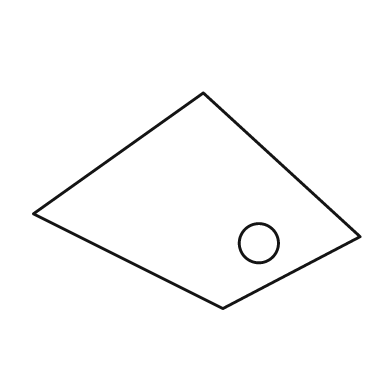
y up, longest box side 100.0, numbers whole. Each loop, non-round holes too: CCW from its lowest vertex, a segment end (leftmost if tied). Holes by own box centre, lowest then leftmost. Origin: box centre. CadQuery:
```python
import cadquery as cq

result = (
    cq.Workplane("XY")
    .moveTo(8.0, -33.0)
    .lineTo(50.0, -11.0)
    .lineTo(2.0, 33.0)
    .lineTo(-50.0, -4.0)
    .close()
    .moveTo(19.0, -13.0)
    .circle(6.0)
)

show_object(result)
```